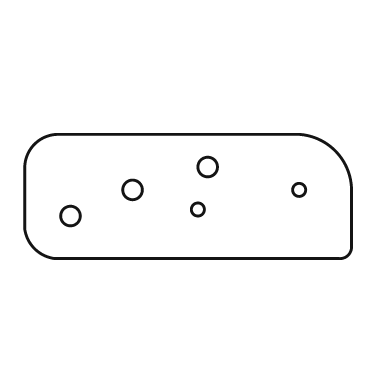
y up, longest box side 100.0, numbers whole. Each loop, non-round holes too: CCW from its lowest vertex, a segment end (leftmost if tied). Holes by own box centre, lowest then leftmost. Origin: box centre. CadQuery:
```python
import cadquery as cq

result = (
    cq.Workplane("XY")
    .moveTo(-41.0, -19.0)
    .lineTo(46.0, -19.0)
    .threePointArc((49.0, -18.0), (50.0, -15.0))
    .lineTo(50.0, 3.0)
    .threePointArc((45.0, 14.0), (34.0, 19.0))
    .lineTo(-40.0, 19.0)
    .threePointArc((-47.0, 16.0), (-50.0, 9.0))
    .lineTo(-50.0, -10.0)
    .threePointArc((-47.0, -16.0), (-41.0, -19.0))
    .close()
    .moveTo(-36.0, -6.0)
    .circle(3.0)
    .moveTo(3.0, -4.0)
    .circle(2.0)
    .moveTo(-17.0, 2.0)
    .circle(3.0)
    .moveTo(34.0, 2.0)
    .circle(2.0)
    .moveTo(6.0, 9.0)
    .circle(3.0)
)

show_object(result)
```